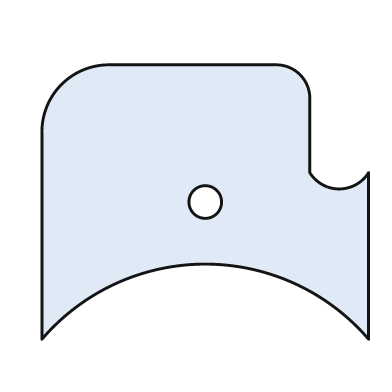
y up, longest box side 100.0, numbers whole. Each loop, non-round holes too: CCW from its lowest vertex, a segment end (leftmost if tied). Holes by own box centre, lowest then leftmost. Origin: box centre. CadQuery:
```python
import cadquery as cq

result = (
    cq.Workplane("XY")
    .moveTo(-50.0, -42.0)
    .threePointArc((0.0, -19.0), (50.0, -42.0))
    .lineTo(50.0, 9.0)
    .threePointArc((41.0, 4.0), (32.0, 9.0))
    .lineTo(32.0, 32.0)
    .threePointArc((29.0, 39.0), (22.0, 42.0))
    .lineTo(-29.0, 42.0)
    .threePointArc((-44.0, 36.0), (-50.0, 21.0))
    .close()
    .moveTo(0.0, 0.0)
    .circle(5.0)
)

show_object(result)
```